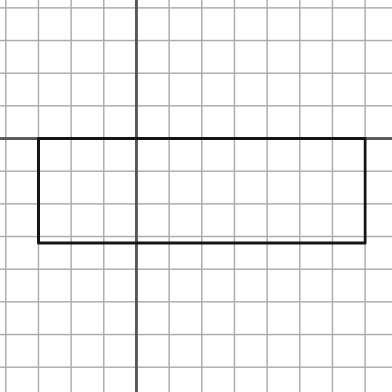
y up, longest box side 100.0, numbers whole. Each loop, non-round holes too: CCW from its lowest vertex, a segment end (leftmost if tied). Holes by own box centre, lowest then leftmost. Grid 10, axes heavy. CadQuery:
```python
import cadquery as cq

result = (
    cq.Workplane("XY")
    .moveTo(-30.0, -32.0)
    .lineTo(70.0, -32.0)
    .lineTo(70.0, 0.0)
    .lineTo(-30.0, 0.0)
    .close()
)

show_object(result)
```